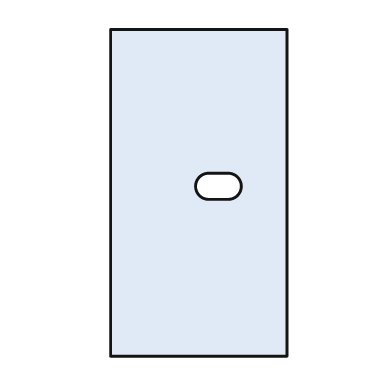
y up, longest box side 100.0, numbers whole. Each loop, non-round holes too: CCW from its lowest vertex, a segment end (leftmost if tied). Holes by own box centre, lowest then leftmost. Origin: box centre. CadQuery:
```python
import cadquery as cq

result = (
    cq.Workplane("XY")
    .moveTo(-27.0, -50.0)
    .lineTo(27.0, -50.0)
    .lineTo(27.0, 50.0)
    .lineTo(-27.0, 50.0)
    .close()
    .moveTo(3.0, -2.0)
    .lineTo(9.0, -2.0)
    .threePointArc((13.0, 2.0), (9.0, 6.0))
    .lineTo(3.0, 6.0)
    .threePointArc((-1.0, 2.0), (3.0, -2.0))
    .close()
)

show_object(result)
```